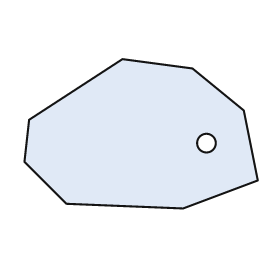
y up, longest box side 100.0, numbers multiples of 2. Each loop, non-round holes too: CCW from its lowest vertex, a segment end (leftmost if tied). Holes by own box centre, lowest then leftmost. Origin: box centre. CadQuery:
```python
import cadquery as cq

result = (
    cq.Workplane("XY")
    .moveTo(18.0, -32.0)
    .lineTo(50.0, -20.0)
    .lineTo(44.0, 10.0)
    .lineTo(22.0, 28.0)
    .lineTo(-8.0, 32.0)
    .lineTo(-48.0, 6.0)
    .lineTo(-50.0, -12.0)
    .lineTo(-32.0, -30.0)
    .close()
    .moveTo(28.0, -4.0)
    .circle(4.0)
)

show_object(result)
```